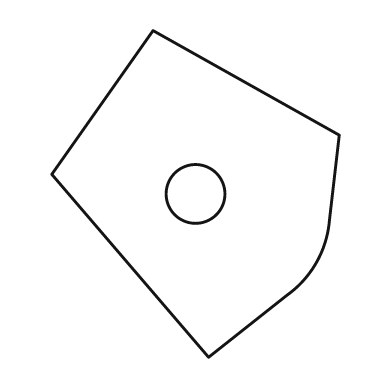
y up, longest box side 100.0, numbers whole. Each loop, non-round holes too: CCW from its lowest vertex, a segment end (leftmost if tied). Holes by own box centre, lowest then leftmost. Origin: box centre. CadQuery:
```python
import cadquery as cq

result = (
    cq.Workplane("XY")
    .moveTo(4.0, -50.0)
    .lineTo(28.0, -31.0)
    .threePointArc((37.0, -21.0), (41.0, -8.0))
    .lineTo(44.0, 18.0)
    .lineTo(-13.0, 50.0)
    .lineTo(-44.0, 6.0)
    .close()
    .moveTo(0.0, 0.0)
    .circle(9.0)
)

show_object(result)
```